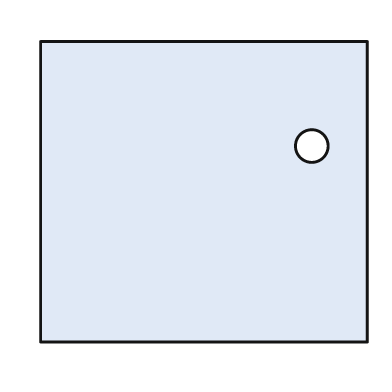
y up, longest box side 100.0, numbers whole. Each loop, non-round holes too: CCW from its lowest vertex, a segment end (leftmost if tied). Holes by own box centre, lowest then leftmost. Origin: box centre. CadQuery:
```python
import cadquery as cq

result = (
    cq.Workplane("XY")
    .moveTo(-50.0, -46.0)
    .lineTo(50.0, -46.0)
    .lineTo(50.0, 46.0)
    .lineTo(-50.0, 46.0)
    .close()
    .moveTo(33.0, 14.0)
    .circle(5.0)
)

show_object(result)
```